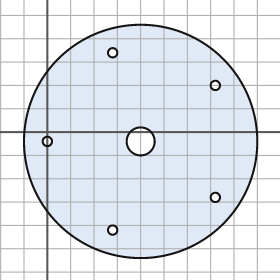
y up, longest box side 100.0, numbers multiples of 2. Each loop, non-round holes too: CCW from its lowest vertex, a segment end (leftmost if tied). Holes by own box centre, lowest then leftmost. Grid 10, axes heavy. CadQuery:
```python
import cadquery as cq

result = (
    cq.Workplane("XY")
    .moveTo(40.0, -4.0)
    .circle(50.0)
    .moveTo(28.0, -42.0)
    .circle(2.0)
    .moveTo(72.0, -28.0)
    .circle(2.0)
    .moveTo(0.0, -4.0)
    .circle(2.0)
    .moveTo(40.0, -4.0)
    .circle(6.0)
    .moveTo(72.0, 20.0)
    .circle(2.0)
    .moveTo(28.0, 34.0)
    .circle(2.0)
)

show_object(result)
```